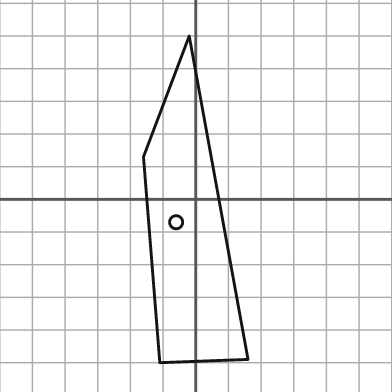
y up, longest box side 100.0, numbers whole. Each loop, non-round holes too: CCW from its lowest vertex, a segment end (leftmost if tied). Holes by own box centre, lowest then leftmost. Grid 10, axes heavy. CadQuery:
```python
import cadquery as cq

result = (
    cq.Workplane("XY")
    .moveTo(-11.0, -50.0)
    .lineTo(16.0, -49.0)
    .lineTo(-2.0, 50.0)
    .lineTo(-16.0, 13.0)
    .close()
    .moveTo(-6.0, -7.0)
    .circle(2.0)
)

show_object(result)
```